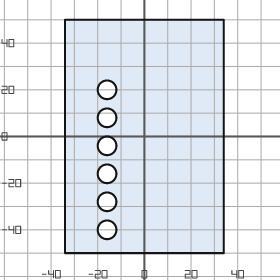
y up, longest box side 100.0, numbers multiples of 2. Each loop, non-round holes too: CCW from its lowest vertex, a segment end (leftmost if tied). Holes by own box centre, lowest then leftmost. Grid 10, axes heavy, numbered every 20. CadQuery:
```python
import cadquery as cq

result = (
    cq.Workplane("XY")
    .moveTo(-34.0, -50.0)
    .lineTo(34.0, -50.0)
    .lineTo(34.0, 50.0)
    .lineTo(-34.0, 50.0)
    .close()
    .moveTo(-16.0, -40.0)
    .circle(4.0)
    .moveTo(-16.0, -28.0)
    .circle(4.0)
    .moveTo(-16.0, -16.0)
    .circle(4.0)
    .moveTo(-16.0, -4.0)
    .circle(4.0)
    .moveTo(-16.0, 8.0)
    .circle(4.0)
    .moveTo(-16.0, 20.0)
    .circle(4.0)
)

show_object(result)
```